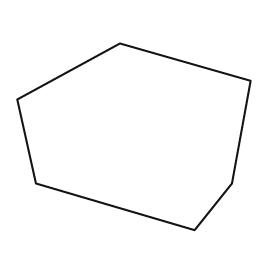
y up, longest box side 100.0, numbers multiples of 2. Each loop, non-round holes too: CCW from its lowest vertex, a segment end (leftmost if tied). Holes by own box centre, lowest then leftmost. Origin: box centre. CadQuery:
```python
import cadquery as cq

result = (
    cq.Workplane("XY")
    .moveTo(26.0, -40.0)
    .lineTo(42.0, -20.0)
    .lineTo(50.0, 24.0)
    .lineTo(-6.0, 40.0)
    .lineTo(-50.0, 16.0)
    .lineTo(-42.0, -20.0)
    .close()
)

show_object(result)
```